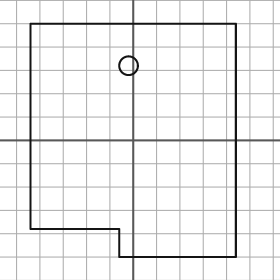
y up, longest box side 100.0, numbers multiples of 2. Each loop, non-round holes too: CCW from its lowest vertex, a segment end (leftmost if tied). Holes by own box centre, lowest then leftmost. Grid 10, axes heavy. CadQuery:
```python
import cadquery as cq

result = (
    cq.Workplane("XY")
    .moveTo(-6.0, -50.0)
    .lineTo(44.0, -50.0)
    .lineTo(44.0, 50.0)
    .lineTo(-44.0, 50.0)
    .lineTo(-44.0, -38.0)
    .lineTo(-6.0, -38.0)
    .close()
    .moveTo(-2.0, 32.0)
    .circle(4.0)
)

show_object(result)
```